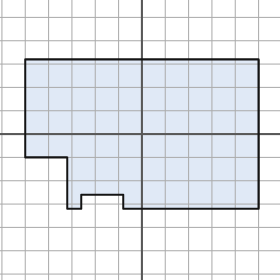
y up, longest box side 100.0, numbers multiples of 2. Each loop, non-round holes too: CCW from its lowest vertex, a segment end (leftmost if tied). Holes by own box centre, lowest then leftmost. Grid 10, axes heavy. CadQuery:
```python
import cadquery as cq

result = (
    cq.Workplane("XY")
    .moveTo(-32.0, -32.0)
    .lineTo(-26.0, -32.0)
    .lineTo(-26.0, -26.0)
    .lineTo(-8.0, -26.0)
    .lineTo(-8.0, -32.0)
    .lineTo(50.0, -32.0)
    .lineTo(50.0, 32.0)
    .lineTo(-50.0, 32.0)
    .lineTo(-50.0, -10.0)
    .lineTo(-32.0, -10.0)
    .close()
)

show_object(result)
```